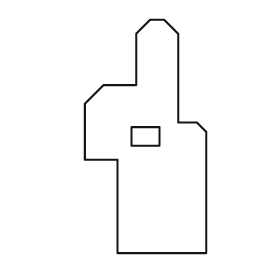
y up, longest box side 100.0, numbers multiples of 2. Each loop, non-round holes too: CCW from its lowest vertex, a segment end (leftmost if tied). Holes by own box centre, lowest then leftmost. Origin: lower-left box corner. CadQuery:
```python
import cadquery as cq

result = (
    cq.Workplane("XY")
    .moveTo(14.0, 0.0)
    .lineTo(52.0, 0.0)
    .lineTo(52.0, 52.0)
    .lineTo(48.0, 56.0)
    .lineTo(40.0, 56.0)
    .lineTo(40.0, 94.0)
    .lineTo(34.0, 100.0)
    .lineTo(28.0, 100.0)
    .lineTo(22.0, 94.0)
    .lineTo(22.0, 72.0)
    .lineTo(8.0, 72.0)
    .lineTo(0.0, 64.0)
    .lineTo(0.0, 40.0)
    .lineTo(14.0, 40.0)
    .close()
    .moveTo(20.0, 46.0)
    .lineTo(32.0, 46.0)
    .lineTo(32.0, 54.0)
    .lineTo(20.0, 54.0)
    .close()
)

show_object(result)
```